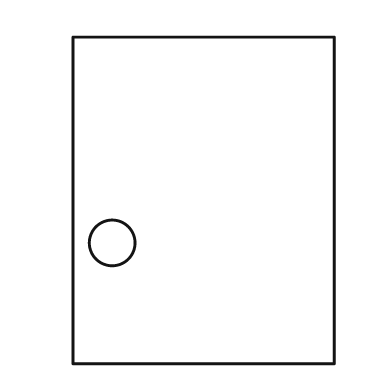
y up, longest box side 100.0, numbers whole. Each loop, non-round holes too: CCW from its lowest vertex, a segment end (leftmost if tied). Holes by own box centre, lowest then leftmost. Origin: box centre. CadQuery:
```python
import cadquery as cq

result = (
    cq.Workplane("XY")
    .moveTo(-40.0, -50.0)
    .lineTo(40.0, -50.0)
    .lineTo(40.0, 50.0)
    .lineTo(-40.0, 50.0)
    .close()
    .moveTo(-28.0, -13.0)
    .circle(7.0)
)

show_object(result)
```